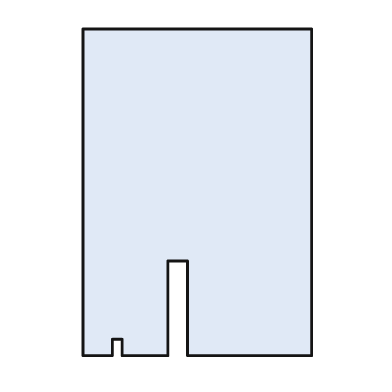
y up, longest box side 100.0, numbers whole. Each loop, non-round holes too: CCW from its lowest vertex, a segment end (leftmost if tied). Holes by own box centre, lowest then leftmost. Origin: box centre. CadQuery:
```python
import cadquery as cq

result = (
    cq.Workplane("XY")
    .moveTo(-35.0, -50.0)
    .lineTo(-26.0, -50.0)
    .lineTo(-26.0, -45.0)
    .lineTo(-23.0, -45.0)
    .lineTo(-23.0, -50.0)
    .lineTo(-9.0, -50.0)
    .lineTo(-9.0, -21.0)
    .lineTo(-3.0, -21.0)
    .lineTo(-3.0, -50.0)
    .lineTo(35.0, -50.0)
    .lineTo(35.0, 50.0)
    .lineTo(-35.0, 50.0)
    .close()
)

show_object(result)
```